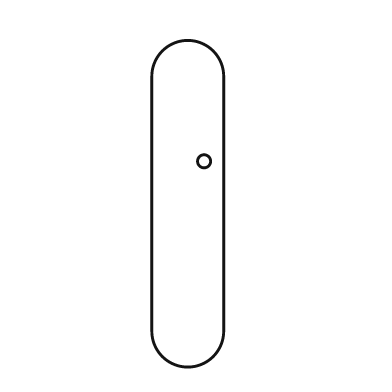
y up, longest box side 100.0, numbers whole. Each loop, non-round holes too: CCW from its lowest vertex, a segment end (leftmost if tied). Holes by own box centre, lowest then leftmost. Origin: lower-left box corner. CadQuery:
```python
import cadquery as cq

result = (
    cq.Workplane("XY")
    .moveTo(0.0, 11.0)
    .threePointArc((11.0, 0.0), (22.0, 11.0))
    .lineTo(22.0, 89.0)
    .threePointArc((11.0, 100.0), (0.0, 89.0))
    .close()
    .moveTo(16.0, 63.0)
    .circle(2.0)
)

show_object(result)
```